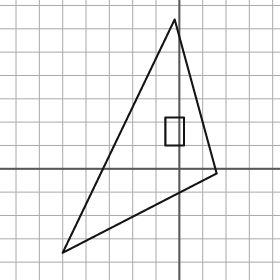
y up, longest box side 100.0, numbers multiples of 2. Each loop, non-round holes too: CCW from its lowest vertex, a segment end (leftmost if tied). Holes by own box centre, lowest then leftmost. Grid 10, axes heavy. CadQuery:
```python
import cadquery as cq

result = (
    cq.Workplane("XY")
    .moveTo(-50.0, -36.0)
    .lineTo(16.0, -2.0)
    .lineTo(-2.0, 64.0)
    .close()
    .moveTo(-6.0, 10.0)
    .lineTo(2.0, 10.0)
    .lineTo(2.0, 22.0)
    .lineTo(-6.0, 22.0)
    .close()
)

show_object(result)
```